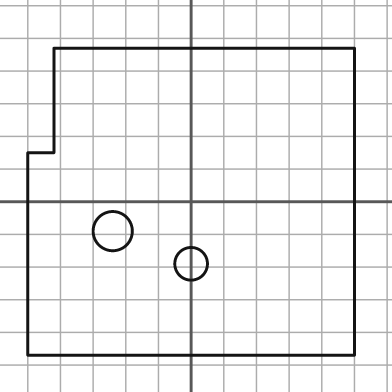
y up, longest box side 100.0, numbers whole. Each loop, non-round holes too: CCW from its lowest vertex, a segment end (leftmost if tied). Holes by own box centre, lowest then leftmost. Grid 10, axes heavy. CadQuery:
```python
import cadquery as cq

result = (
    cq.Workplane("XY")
    .moveTo(-50.0, -47.0)
    .lineTo(50.0, -47.0)
    .lineTo(50.0, 47.0)
    .lineTo(-42.0, 47.0)
    .lineTo(-42.0, 15.0)
    .lineTo(-50.0, 15.0)
    .close()
    .moveTo(0.0, -19.0)
    .circle(5.0)
    .moveTo(-24.0, -9.0)
    .circle(6.0)
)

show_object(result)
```